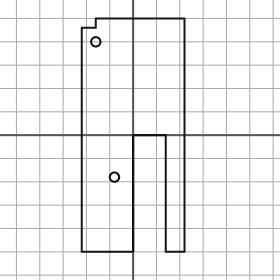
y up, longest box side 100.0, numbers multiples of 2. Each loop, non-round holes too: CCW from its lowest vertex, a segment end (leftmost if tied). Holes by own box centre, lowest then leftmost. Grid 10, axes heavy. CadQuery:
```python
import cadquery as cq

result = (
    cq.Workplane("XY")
    .moveTo(-22.0, -50.0)
    .lineTo(0.0, -50.0)
    .lineTo(0.0, 0.0)
    .lineTo(14.0, 0.0)
    .lineTo(14.0, -50.0)
    .lineTo(22.0, -50.0)
    .lineTo(22.0, 50.0)
    .lineTo(-16.0, 50.0)
    .lineTo(-16.0, 46.0)
    .lineTo(-22.0, 46.0)
    .close()
    .moveTo(-8.0, -18.0)
    .circle(2.0)
    .moveTo(-16.0, 40.0)
    .circle(2.0)
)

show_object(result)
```